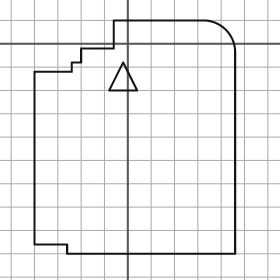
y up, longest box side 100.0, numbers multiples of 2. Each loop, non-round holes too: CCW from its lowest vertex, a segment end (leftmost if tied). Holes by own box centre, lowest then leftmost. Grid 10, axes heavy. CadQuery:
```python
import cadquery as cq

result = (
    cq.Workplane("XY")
    .moveTo(-26.0, -90.0)
    .lineTo(46.0, -90.0)
    .lineTo(46.0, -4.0)
    .threePointArc((42.0, 6.0), (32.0, 10.0))
    .lineTo(-6.0, 10.0)
    .lineTo(-6.0, -2.0)
    .lineTo(-20.0, -2.0)
    .lineTo(-20.0, -8.0)
    .lineTo(-24.0, -8.0)
    .lineTo(-24.0, -12.0)
    .lineTo(-40.0, -12.0)
    .lineTo(-40.0, -86.0)
    .lineTo(-26.0, -86.0)
    .close()
    .moveTo(-8.0, -20.0)
    .lineTo(4.0, -20.0)
    .lineTo(-2.0, -8.0)
    .close()
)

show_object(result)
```